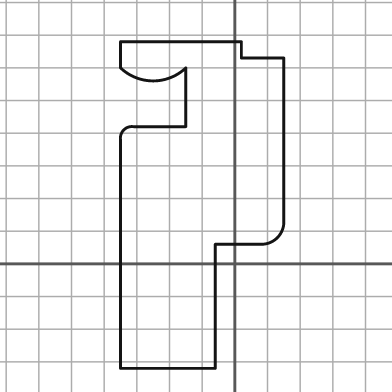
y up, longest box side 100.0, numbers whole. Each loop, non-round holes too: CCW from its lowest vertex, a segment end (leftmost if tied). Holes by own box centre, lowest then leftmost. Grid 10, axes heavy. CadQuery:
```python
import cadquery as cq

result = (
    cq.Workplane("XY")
    .moveTo(-35.0, -32.0)
    .lineTo(-6.0, -32.0)
    .lineTo(-6.0, 6.0)
    .lineTo(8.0, 6.0)
    .threePointArc((13.0, 8.0), (15.0, 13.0))
    .lineTo(15.0, 63.0)
    .lineTo(2.0, 63.0)
    .lineTo(2.0, 68.0)
    .lineTo(-35.0, 68.0)
    .lineTo(-35.0, 60.0)
    .threePointArc((-25.0, 56.0), (-15.0, 60.0))
    .lineTo(-15.0, 42.0)
    .lineTo(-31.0, 42.0)
    .threePointArc((-34.0, 41.0), (-35.0, 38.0))
    .close()
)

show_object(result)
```